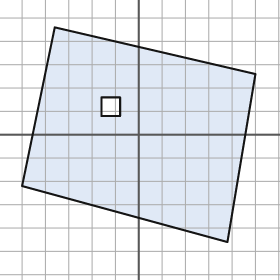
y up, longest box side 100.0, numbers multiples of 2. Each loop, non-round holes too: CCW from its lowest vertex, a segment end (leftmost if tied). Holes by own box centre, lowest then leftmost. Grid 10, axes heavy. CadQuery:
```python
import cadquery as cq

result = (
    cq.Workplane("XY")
    .moveTo(38.0, -46.0)
    .lineTo(50.0, 26.0)
    .lineTo(-36.0, 46.0)
    .lineTo(-50.0, -22.0)
    .close()
    .moveTo(-16.0, 8.0)
    .lineTo(-8.0, 8.0)
    .lineTo(-8.0, 16.0)
    .lineTo(-16.0, 16.0)
    .close()
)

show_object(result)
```